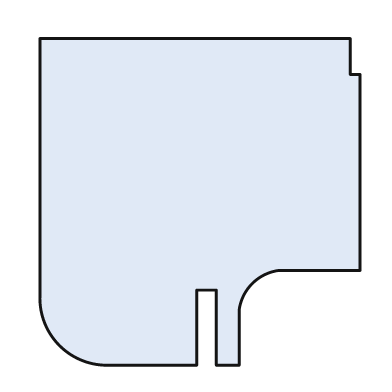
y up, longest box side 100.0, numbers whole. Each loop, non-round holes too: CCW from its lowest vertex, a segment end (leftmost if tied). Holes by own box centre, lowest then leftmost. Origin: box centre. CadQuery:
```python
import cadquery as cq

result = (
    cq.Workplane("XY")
    .moveTo(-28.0, -50.0)
    .lineTo(-1.0, -50.0)
    .lineTo(-1.0, -27.0)
    .lineTo(5.0, -27.0)
    .lineTo(5.0, -50.0)
    .lineTo(12.0, -50.0)
    .lineTo(12.0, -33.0)
    .threePointArc((16.0, -25.0), (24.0, -21.0))
    .lineTo(49.0, -21.0)
    .lineTo(49.0, 39.0)
    .lineTo(46.0, 39.0)
    .lineTo(46.0, 50.0)
    .lineTo(-49.0, 50.0)
    .lineTo(-49.0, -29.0)
    .threePointArc((-43.0, -44.0), (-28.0, -50.0))
    .close()
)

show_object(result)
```